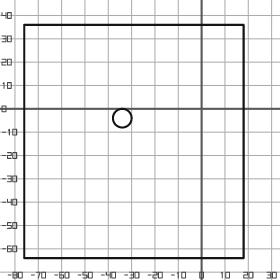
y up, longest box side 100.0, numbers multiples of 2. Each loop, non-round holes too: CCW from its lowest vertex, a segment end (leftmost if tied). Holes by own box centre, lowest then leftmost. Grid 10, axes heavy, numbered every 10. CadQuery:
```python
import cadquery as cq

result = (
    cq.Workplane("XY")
    .moveTo(-76.0, -64.0)
    .lineTo(18.0, -64.0)
    .lineTo(18.0, 36.0)
    .lineTo(-76.0, 36.0)
    .close()
    .moveTo(-34.0, -4.0)
    .circle(4.0)
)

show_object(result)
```